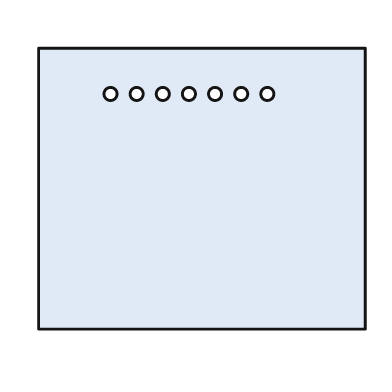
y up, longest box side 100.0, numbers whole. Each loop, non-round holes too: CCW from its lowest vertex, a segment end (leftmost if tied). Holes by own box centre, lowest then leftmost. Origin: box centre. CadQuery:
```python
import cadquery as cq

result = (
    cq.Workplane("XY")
    .moveTo(-50.0, -43.0)
    .lineTo(50.0, -43.0)
    .lineTo(50.0, 43.0)
    .lineTo(-50.0, 43.0)
    .close()
    .moveTo(-28.0, 29.0)
    .circle(2.0)
    .moveTo(-20.0, 29.0)
    .circle(2.0)
    .moveTo(-12.0, 29.0)
    .circle(2.0)
    .moveTo(-4.0, 29.0)
    .circle(2.0)
    .moveTo(4.0, 29.0)
    .circle(2.0)
    .moveTo(12.0, 29.0)
    .circle(2.0)
    .moveTo(20.0, 29.0)
    .circle(2.0)
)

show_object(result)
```